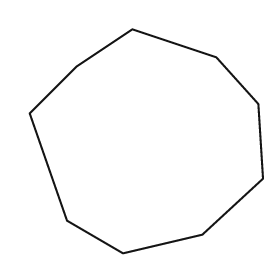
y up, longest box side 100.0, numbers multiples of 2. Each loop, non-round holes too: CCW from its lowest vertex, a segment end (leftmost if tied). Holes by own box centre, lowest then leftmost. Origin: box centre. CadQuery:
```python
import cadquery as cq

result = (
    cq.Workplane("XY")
    .moveTo(-10.0, -48.0)
    .lineTo(24.0, -40.0)
    .lineTo(50.0, -16.0)
    .lineTo(48.0, 16.0)
    .lineTo(30.0, 36.0)
    .lineTo(-6.0, 48.0)
    .lineTo(-30.0, 32.0)
    .lineTo(-50.0, 12.0)
    .lineTo(-34.0, -34.0)
    .close()
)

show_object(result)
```